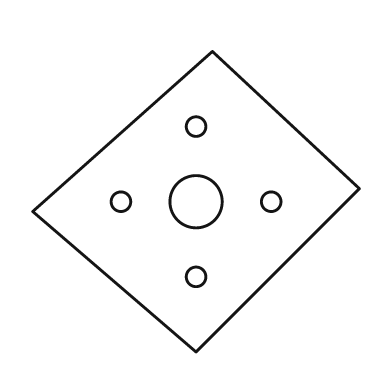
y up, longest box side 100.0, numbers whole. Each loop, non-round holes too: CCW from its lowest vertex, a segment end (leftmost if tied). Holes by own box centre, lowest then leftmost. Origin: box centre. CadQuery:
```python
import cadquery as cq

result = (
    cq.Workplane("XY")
    .moveTo(0.0, -46.0)
    .lineTo(50.0, 4.0)
    .lineTo(5.0, 46.0)
    .lineTo(-50.0, -3.0)
    .close()
    .moveTo(0.0, -23.0)
    .circle(3.0)
    .moveTo(-23.0, 0.0)
    .circle(3.0)
    .moveTo(0.0, 0.0)
    .circle(8.0)
    .moveTo(23.0, 0.0)
    .circle(3.0)
    .moveTo(0.0, 23.0)
    .circle(3.0)
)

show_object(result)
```